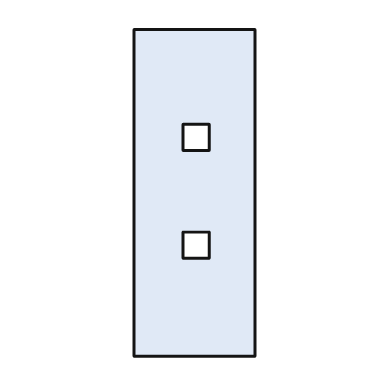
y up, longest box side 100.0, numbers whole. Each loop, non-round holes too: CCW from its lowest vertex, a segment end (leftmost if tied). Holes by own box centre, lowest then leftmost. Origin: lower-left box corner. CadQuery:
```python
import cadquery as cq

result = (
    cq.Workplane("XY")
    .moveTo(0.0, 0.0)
    .lineTo(37.0, 0.0)
    .lineTo(37.0, 100.0)
    .lineTo(0.0, 100.0)
    .close()
    .moveTo(15.0, 30.0)
    .lineTo(23.0, 30.0)
    .lineTo(23.0, 38.0)
    .lineTo(15.0, 38.0)
    .close()
    .moveTo(15.0, 63.0)
    .lineTo(23.0, 63.0)
    .lineTo(23.0, 71.0)
    .lineTo(15.0, 71.0)
    .close()
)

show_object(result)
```